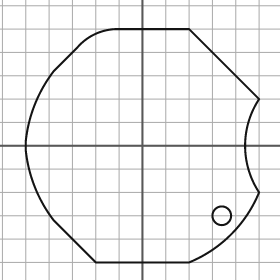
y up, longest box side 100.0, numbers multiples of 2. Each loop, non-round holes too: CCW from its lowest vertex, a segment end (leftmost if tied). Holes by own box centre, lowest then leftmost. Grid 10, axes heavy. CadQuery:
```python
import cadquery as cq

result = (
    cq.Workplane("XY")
    .moveTo(-20.0, -50.0)
    .lineTo(20.0, -50.0)
    .threePointArc((38.0, -38.0), (50.0, -20.0))
    .threePointArc((44.0, 0.0), (50.0, 20.0))
    .lineTo(20.0, 50.0)
    .lineTo(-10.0, 50.0)
    .threePointArc((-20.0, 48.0), (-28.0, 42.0))
    .lineTo(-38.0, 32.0)
    .threePointArc((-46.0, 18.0), (-50.0, 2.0))
    .lineTo(-50.0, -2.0)
    .threePointArc((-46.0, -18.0), (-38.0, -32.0))
    .close()
    .moveTo(34.0, -30.0)
    .circle(4.0)
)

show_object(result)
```